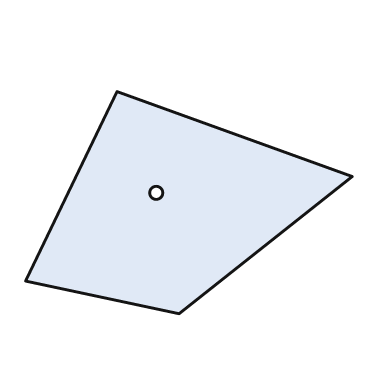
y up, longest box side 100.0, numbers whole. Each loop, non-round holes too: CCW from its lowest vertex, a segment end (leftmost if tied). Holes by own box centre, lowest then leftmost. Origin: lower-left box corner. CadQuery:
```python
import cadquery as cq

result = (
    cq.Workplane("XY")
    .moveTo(47.0, 0.0)
    .lineTo(100.0, 42.0)
    .lineTo(28.0, 68.0)
    .lineTo(0.0, 10.0)
    .close()
    .moveTo(40.0, 37.0)
    .circle(2.0)
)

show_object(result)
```